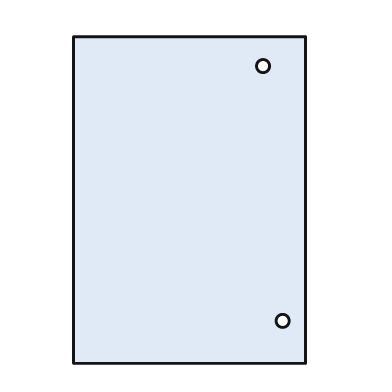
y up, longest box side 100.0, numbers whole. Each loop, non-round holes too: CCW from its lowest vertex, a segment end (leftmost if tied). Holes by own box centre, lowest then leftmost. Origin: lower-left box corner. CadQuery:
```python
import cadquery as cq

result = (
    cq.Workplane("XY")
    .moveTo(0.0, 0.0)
    .lineTo(71.0, 0.0)
    .lineTo(71.0, 100.0)
    .lineTo(0.0, 100.0)
    .close()
    .moveTo(64.0, 13.0)
    .circle(2.0)
    .moveTo(58.0, 91.0)
    .circle(2.0)
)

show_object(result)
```